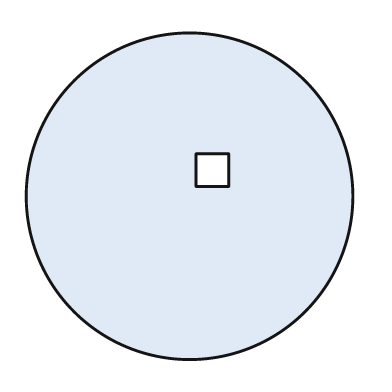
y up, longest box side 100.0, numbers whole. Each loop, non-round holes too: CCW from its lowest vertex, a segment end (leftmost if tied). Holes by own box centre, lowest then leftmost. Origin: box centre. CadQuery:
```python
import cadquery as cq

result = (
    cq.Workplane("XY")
    .moveTo(0.0, 0.0)
    .circle(50.0)
    .moveTo(2.0, 3.0)
    .lineTo(12.0, 3.0)
    .lineTo(12.0, 13.0)
    .lineTo(2.0, 13.0)
    .close()
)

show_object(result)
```